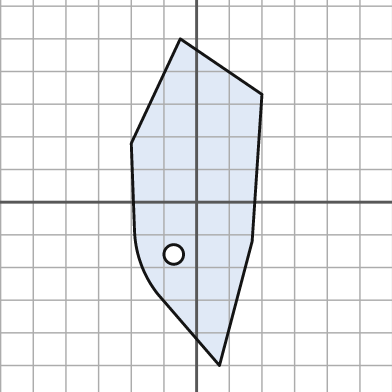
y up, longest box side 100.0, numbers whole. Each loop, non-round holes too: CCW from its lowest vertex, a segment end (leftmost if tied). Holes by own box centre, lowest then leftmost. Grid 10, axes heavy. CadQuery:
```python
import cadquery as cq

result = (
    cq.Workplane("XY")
    .moveTo(7.0, -50.0)
    .lineTo(17.0, -12.0)
    .lineTo(20.0, 33.0)
    .lineTo(-5.0, 50.0)
    .lineTo(-20.0, 18.0)
    .lineTo(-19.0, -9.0)
    .threePointArc((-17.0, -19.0), (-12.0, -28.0))
    .close()
    .moveTo(-7.0, -16.0)
    .circle(3.0)
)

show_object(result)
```